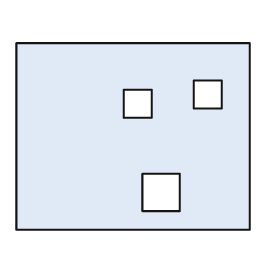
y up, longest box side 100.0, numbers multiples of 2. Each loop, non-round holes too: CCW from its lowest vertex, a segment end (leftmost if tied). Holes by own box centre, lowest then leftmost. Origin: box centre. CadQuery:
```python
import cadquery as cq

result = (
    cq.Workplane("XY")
    .moveTo(-50.0, -40.0)
    .lineTo(50.0, -40.0)
    .lineTo(50.0, 40.0)
    .lineTo(-50.0, 40.0)
    .close()
    .moveTo(4.0, -32.0)
    .lineTo(20.0, -32.0)
    .lineTo(20.0, -16.0)
    .lineTo(4.0, -16.0)
    .close()
    .moveTo(-4.0, 8.0)
    .lineTo(8.0, 8.0)
    .lineTo(8.0, 20.0)
    .lineTo(-4.0, 20.0)
    .close()
    .moveTo(26.0, 12.0)
    .lineTo(38.0, 12.0)
    .lineTo(38.0, 24.0)
    .lineTo(26.0, 24.0)
    .close()
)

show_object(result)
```